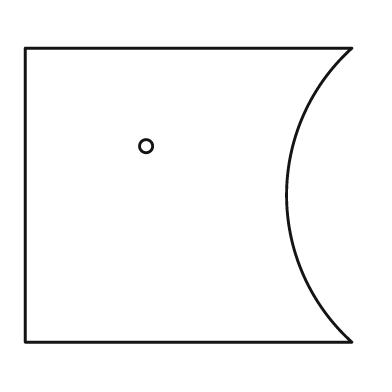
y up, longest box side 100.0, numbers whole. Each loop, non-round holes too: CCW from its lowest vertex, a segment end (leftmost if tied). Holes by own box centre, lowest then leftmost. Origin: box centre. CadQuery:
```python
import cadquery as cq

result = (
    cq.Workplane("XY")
    .moveTo(-50.0, -45.0)
    .lineTo(50.0, -45.0)
    .threePointArc((30.0, 0.0), (50.0, 45.0))
    .lineTo(-50.0, 45.0)
    .close()
    .moveTo(-13.0, 15.0)
    .circle(2.0)
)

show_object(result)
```